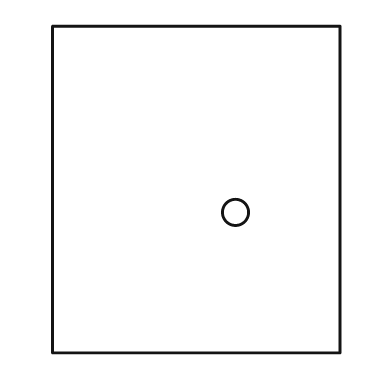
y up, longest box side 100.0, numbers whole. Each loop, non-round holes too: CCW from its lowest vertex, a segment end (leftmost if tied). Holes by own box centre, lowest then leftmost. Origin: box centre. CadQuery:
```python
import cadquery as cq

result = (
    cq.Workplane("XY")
    .moveTo(-44.0, -50.0)
    .lineTo(44.0, -50.0)
    .lineTo(44.0, 50.0)
    .lineTo(-44.0, 50.0)
    .close()
    .moveTo(12.0, -7.0)
    .circle(4.0)
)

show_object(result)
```